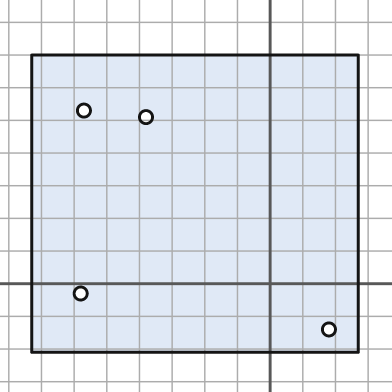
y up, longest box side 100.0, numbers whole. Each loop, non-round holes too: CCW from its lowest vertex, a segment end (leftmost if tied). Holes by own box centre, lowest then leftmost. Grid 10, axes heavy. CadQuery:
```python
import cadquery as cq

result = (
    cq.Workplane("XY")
    .moveTo(-73.0, -21.0)
    .lineTo(27.0, -21.0)
    .lineTo(27.0, 70.0)
    .lineTo(-73.0, 70.0)
    .close()
    .moveTo(18.0, -14.0)
    .circle(2.0)
    .moveTo(-58.0, -3.0)
    .circle(2.0)
    .moveTo(-38.0, 51.0)
    .circle(2.0)
    .moveTo(-57.0, 53.0)
    .circle(2.0)
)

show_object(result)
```